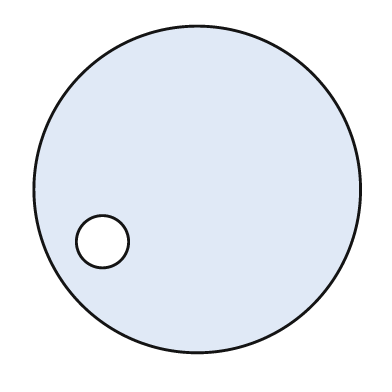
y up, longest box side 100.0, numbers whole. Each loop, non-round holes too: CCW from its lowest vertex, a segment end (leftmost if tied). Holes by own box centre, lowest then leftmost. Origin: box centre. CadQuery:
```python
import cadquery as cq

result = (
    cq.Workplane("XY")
    .moveTo(0.0, 0.0)
    .circle(50.0)
    .moveTo(-29.0, -16.0)
    .circle(8.0)
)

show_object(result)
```